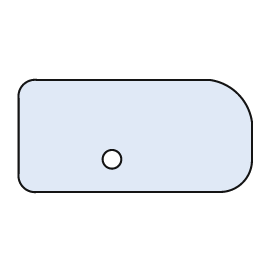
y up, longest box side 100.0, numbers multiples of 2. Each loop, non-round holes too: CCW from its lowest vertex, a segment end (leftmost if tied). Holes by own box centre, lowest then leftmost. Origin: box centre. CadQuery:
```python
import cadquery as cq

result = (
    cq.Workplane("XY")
    .moveTo(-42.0, -24.0)
    .lineTo(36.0, -24.0)
    .threePointArc((46.0, -20.0), (50.0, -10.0))
    .lineTo(50.0, 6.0)
    .threePointArc((44.0, 18.0), (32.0, 24.0))
    .lineTo(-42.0, 24.0)
    .threePointArc((-48.0, 22.0), (-50.0, 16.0))
    .lineTo(-50.0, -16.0)
    .threePointArc((-48.0, -22.0), (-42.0, -24.0))
    .close()
    .moveTo(-10.0, -10.0)
    .circle(4.0)
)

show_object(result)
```